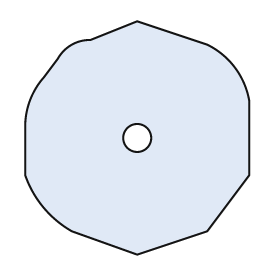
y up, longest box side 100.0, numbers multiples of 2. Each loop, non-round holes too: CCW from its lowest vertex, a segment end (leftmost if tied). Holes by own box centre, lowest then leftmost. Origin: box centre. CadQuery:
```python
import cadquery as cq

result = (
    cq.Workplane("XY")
    .moveTo(0.0, -50.0)
    .lineTo(30.0, -40.0)
    .lineTo(48.0, -16.0)
    .lineTo(48.0, 16.0)
    .threePointArc((42.0, 30.0), (30.0, 40.0))
    .lineTo(0.0, 50.0)
    .lineTo(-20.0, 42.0)
    .threePointArc((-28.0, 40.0), (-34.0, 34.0))
    .lineTo(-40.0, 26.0)
    .threePointArc((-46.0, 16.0), (-48.0, 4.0))
    .lineTo(-48.0, -16.0)
    .threePointArc((-40.0, -30.0), (-28.0, -40.0))
    .close()
    .moveTo(0.0, 0.0)
    .circle(6.0)
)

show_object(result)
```